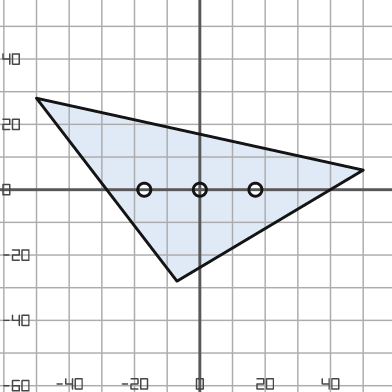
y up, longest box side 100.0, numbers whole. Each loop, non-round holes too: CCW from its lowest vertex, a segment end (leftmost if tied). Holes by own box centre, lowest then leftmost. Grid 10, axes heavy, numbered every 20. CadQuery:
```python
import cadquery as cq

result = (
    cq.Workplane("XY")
    .moveTo(-7.0, -28.0)
    .lineTo(50.0, 6.0)
    .lineTo(-50.0, 28.0)
    .close()
    .moveTo(-17.0, 0.0)
    .circle(2.0)
    .moveTo(0.0, 0.0)
    .circle(2.0)
    .moveTo(17.0, 0.0)
    .circle(2.0)
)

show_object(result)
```